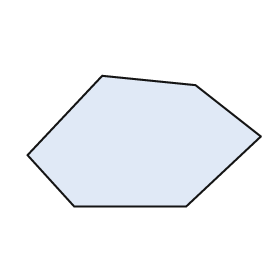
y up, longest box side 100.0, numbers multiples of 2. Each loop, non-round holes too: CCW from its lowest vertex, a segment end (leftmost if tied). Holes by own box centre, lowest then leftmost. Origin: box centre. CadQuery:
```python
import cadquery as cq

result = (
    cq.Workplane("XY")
    .moveTo(-30.0, -28.0)
    .lineTo(18.0, -28.0)
    .lineTo(50.0, 2.0)
    .lineTo(22.0, 24.0)
    .lineTo(-18.0, 28.0)
    .lineTo(-50.0, -6.0)
    .close()
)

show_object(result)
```